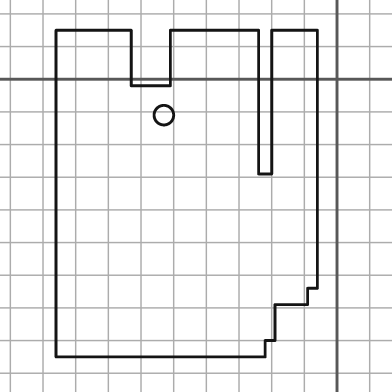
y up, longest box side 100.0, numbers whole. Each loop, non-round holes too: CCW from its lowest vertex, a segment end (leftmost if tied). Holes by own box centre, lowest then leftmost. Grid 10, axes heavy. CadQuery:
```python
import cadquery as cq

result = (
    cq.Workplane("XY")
    .moveTo(-86.0, -85.0)
    .lineTo(-22.0, -85.0)
    .lineTo(-22.0, -80.0)
    .lineTo(-19.0, -80.0)
    .lineTo(-19.0, -69.0)
    .lineTo(-9.0, -69.0)
    .lineTo(-9.0, -64.0)
    .lineTo(-6.0, -64.0)
    .lineTo(-6.0, 15.0)
    .lineTo(-20.0, 15.0)
    .lineTo(-20.0, -29.0)
    .lineTo(-24.0, -29.0)
    .lineTo(-24.0, 15.0)
    .lineTo(-51.0, 15.0)
    .lineTo(-51.0, -2.0)
    .lineTo(-63.0, -2.0)
    .lineTo(-63.0, 15.0)
    .lineTo(-86.0, 15.0)
    .close()
    .moveTo(-53.0, -11.0)
    .circle(3.0)
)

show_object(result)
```